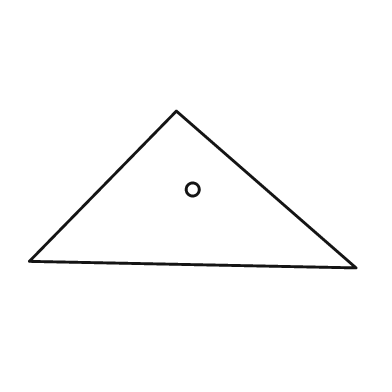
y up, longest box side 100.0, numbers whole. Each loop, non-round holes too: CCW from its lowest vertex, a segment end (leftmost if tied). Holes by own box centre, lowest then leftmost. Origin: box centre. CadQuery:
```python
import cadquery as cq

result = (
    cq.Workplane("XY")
    .moveTo(50.0, -24.0)
    .lineTo(-5.0, 24.0)
    .lineTo(-50.0, -22.0)
    .close()
    .moveTo(0.0, 0.0)
    .circle(2.0)
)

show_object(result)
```